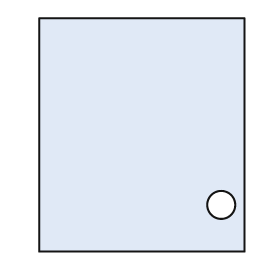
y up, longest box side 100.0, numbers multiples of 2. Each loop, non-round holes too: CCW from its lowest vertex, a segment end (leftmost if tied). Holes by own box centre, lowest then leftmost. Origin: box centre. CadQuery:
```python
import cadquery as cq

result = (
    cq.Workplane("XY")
    .moveTo(-44.0, -50.0)
    .lineTo(44.0, -50.0)
    .lineTo(44.0, 50.0)
    .lineTo(-44.0, 50.0)
    .close()
    .moveTo(34.0, -30.0)
    .circle(6.0)
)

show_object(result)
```